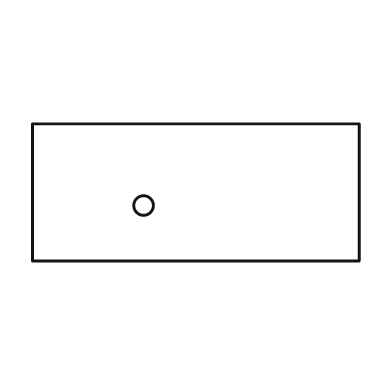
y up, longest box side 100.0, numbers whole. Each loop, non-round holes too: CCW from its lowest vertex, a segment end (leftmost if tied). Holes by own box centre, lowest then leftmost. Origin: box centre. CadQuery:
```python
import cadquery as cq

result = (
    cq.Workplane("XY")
    .moveTo(-50.0, -21.0)
    .lineTo(50.0, -21.0)
    .lineTo(50.0, 21.0)
    .lineTo(-50.0, 21.0)
    .close()
    .moveTo(-16.0, -4.0)
    .circle(3.0)
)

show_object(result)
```